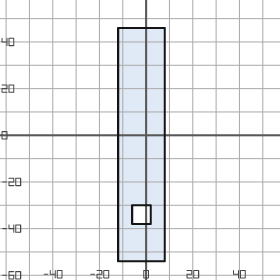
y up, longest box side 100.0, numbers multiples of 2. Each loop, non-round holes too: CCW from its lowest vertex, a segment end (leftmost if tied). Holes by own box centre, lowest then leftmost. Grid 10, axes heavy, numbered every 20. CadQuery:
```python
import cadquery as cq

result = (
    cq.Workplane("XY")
    .moveTo(-12.0, -54.0)
    .lineTo(8.0, -54.0)
    .lineTo(8.0, 46.0)
    .lineTo(-12.0, 46.0)
    .close()
    .moveTo(-6.0, -38.0)
    .lineTo(2.0, -38.0)
    .lineTo(2.0, -30.0)
    .lineTo(-6.0, -30.0)
    .close()
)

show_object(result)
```